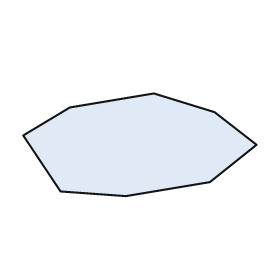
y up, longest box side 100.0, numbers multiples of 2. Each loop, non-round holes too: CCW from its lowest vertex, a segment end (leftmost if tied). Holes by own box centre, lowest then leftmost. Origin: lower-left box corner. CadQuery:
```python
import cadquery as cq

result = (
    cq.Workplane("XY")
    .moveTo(44.0, 0.0)
    .lineTo(80.0, 6.0)
    .lineTo(100.0, 22.0)
    .lineTo(82.0, 36.0)
    .lineTo(56.0, 44.0)
    .lineTo(20.0, 38.0)
    .lineTo(0.0, 26.0)
    .lineTo(16.0, 2.0)
    .close()
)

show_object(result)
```